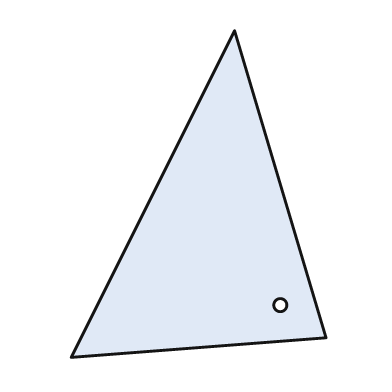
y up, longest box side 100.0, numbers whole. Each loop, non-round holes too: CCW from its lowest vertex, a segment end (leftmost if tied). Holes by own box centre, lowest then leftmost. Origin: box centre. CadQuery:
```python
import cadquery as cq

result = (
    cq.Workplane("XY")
    .moveTo(-39.0, -50.0)
    .lineTo(39.0, -44.0)
    .lineTo(11.0, 50.0)
    .close()
    .moveTo(25.0, -34.0)
    .circle(2.0)
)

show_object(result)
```